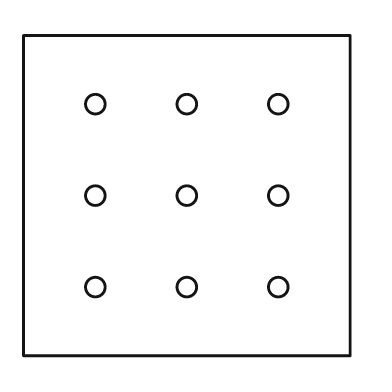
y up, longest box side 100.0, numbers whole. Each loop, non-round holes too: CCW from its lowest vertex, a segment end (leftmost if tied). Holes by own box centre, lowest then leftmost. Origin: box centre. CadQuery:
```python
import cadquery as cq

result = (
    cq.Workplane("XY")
    .moveTo(-50.0, -49.0)
    .lineTo(50.0, -49.0)
    .lineTo(50.0, 49.0)
    .lineTo(-50.0, 49.0)
    .close()
    .moveTo(-28.0, -28.0)
    .circle(3.0)
    .moveTo(0.0, -28.0)
    .circle(3.0)
    .moveTo(28.0, -28.0)
    .circle(3.0)
    .moveTo(-28.0, 0.0)
    .circle(3.0)
    .moveTo(0.0, 0.0)
    .circle(3.0)
    .moveTo(28.0, 0.0)
    .circle(3.0)
    .moveTo(-28.0, 28.0)
    .circle(3.0)
    .moveTo(0.0, 28.0)
    .circle(3.0)
    .moveTo(28.0, 28.0)
    .circle(3.0)
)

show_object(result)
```